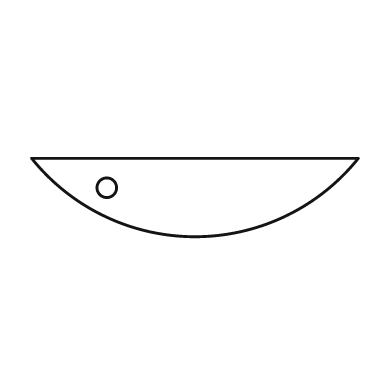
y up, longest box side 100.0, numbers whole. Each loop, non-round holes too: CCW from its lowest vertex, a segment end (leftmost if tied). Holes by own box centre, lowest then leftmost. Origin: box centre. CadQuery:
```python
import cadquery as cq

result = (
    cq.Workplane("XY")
    .moveTo(-50.0, 12.0)
    .threePointArc((0.0, -12.0), (50.0, 12.0))
    .close()
    .moveTo(-27.0, 3.0)
    .circle(3.0)
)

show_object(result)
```